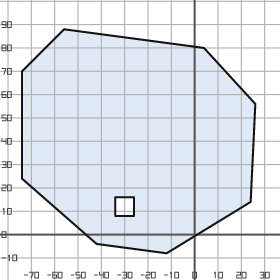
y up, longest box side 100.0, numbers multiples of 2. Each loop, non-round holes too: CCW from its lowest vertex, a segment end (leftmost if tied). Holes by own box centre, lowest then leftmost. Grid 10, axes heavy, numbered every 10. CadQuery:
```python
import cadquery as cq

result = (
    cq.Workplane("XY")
    .moveTo(-12.0, -8.0)
    .lineTo(24.0, 14.0)
    .lineTo(26.0, 56.0)
    .lineTo(4.0, 80.0)
    .lineTo(-56.0, 88.0)
    .lineTo(-74.0, 70.0)
    .lineTo(-74.0, 24.0)
    .lineTo(-42.0, -4.0)
    .close()
    .moveTo(-34.0, 8.0)
    .lineTo(-26.0, 8.0)
    .lineTo(-26.0, 16.0)
    .lineTo(-34.0, 16.0)
    .close()
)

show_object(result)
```